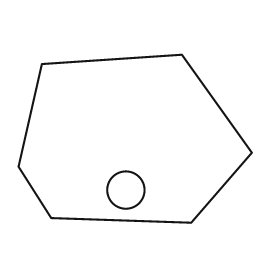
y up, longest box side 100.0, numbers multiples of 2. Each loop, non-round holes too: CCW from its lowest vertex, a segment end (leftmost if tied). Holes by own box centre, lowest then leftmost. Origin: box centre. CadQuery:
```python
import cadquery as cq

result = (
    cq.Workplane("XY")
    .moveTo(24.0, -36.0)
    .lineTo(50.0, -6.0)
    .lineTo(20.0, 36.0)
    .lineTo(-40.0, 32.0)
    .lineTo(-50.0, -12.0)
    .lineTo(-36.0, -34.0)
    .close()
    .moveTo(-4.0, -22.0)
    .circle(8.0)
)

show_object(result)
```